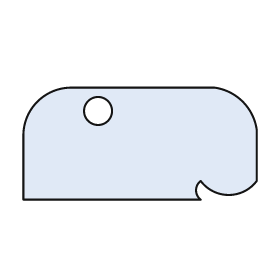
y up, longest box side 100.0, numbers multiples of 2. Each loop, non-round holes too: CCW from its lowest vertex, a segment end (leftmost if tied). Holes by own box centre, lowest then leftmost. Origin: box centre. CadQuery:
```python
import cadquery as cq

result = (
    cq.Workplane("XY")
    .moveTo(-50.0, -24.0)
    .lineTo(26.0, -24.0)
    .threePointArc((24.0, -20.0), (26.0, -16.0))
    .threePointArc((38.0, -22.0), (50.0, -16.0))
    .lineTo(50.0, 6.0)
    .threePointArc((44.0, 18.0), (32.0, 24.0))
    .lineTo(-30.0, 24.0)
    .threePointArc((-44.0, 18.0), (-50.0, 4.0))
    .close()
    .moveTo(-18.0, 14.0)
    .circle(6.0)
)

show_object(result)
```